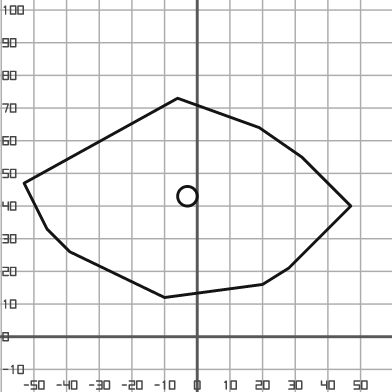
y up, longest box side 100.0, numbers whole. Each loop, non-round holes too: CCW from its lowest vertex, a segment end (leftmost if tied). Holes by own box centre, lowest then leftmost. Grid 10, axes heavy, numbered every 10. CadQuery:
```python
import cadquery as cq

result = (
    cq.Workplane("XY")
    .moveTo(-10.0, 12.0)
    .lineTo(20.0, 16.0)
    .lineTo(28.0, 21.0)
    .lineTo(47.0, 40.0)
    .lineTo(32.0, 55.0)
    .lineTo(19.0, 64.0)
    .lineTo(-6.0, 73.0)
    .lineTo(-53.0, 47.0)
    .lineTo(-46.0, 33.0)
    .lineTo(-39.0, 26.0)
    .close()
    .moveTo(-3.0, 43.0)
    .circle(3.0)
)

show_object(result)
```